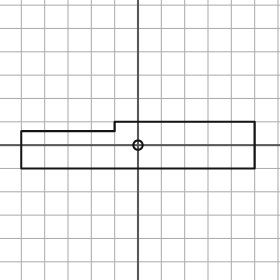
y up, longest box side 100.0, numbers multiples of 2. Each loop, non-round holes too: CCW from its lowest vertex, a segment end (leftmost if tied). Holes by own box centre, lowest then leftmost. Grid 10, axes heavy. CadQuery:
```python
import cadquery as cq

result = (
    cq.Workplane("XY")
    .moveTo(-50.0, -10.0)
    .lineTo(50.0, -10.0)
    .lineTo(50.0, 10.0)
    .lineTo(-10.0, 10.0)
    .lineTo(-10.0, 6.0)
    .lineTo(-50.0, 6.0)
    .close()
    .moveTo(0.0, 0.0)
    .circle(2.0)
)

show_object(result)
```